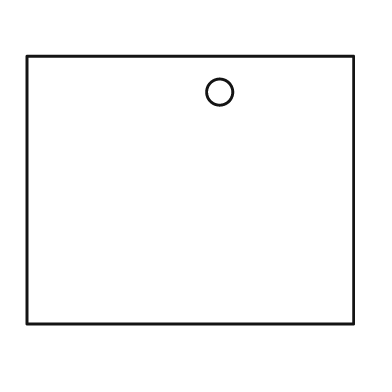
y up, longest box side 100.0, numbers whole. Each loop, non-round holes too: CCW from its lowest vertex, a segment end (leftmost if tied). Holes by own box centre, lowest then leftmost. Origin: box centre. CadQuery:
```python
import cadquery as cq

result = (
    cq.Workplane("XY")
    .moveTo(-50.0, -41.0)
    .lineTo(50.0, -41.0)
    .lineTo(50.0, 41.0)
    .lineTo(-50.0, 41.0)
    .close()
    .moveTo(9.0, 30.0)
    .circle(4.0)
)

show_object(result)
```